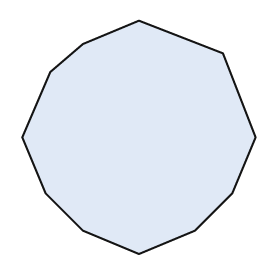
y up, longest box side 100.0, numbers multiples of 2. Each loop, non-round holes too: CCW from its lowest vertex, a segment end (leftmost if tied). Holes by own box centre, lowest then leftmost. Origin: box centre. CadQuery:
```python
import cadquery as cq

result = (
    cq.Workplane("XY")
    .moveTo(0.0, -50.0)
    .lineTo(24.0, -40.0)
    .lineTo(40.0, -24.0)
    .lineTo(50.0, 0.0)
    .lineTo(36.0, 36.0)
    .lineTo(0.0, 50.0)
    .lineTo(-24.0, 40.0)
    .lineTo(-38.0, 28.0)
    .lineTo(-50.0, 0.0)
    .lineTo(-40.0, -24.0)
    .lineTo(-24.0, -40.0)
    .close()
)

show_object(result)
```